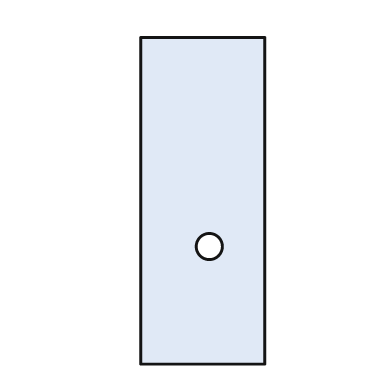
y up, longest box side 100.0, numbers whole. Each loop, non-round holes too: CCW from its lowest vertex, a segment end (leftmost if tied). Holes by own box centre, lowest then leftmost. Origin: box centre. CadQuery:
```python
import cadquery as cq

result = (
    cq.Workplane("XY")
    .moveTo(-19.0, -50.0)
    .lineTo(19.0, -50.0)
    .lineTo(19.0, 50.0)
    .lineTo(-19.0, 50.0)
    .close()
    .moveTo(2.0, -14.0)
    .circle(4.0)
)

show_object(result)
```